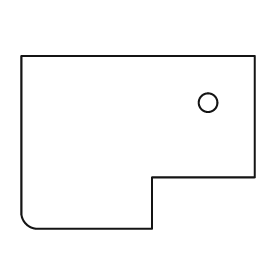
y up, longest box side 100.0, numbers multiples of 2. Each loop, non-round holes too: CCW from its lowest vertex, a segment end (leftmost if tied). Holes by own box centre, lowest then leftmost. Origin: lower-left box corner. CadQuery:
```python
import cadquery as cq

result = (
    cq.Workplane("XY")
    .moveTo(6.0, 0.0)
    .lineTo(56.0, 0.0)
    .lineTo(56.0, 22.0)
    .lineTo(100.0, 22.0)
    .lineTo(100.0, 74.0)
    .lineTo(0.0, 74.0)
    .lineTo(0.0, 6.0)
    .threePointArc((2.0, 2.0), (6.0, 0.0))
    .close()
    .moveTo(80.0, 54.0)
    .circle(4.0)
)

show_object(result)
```